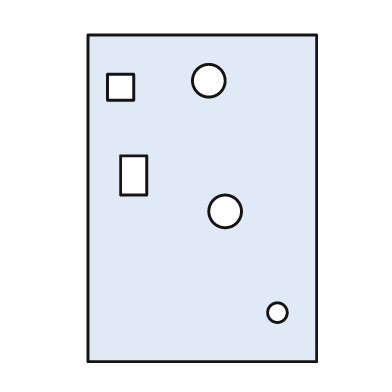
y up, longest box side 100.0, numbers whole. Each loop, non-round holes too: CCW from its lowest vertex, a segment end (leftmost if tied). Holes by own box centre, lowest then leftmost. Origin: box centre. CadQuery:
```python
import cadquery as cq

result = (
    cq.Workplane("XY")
    .moveTo(-35.0, -50.0)
    .lineTo(35.0, -50.0)
    .lineTo(35.0, 50.0)
    .lineTo(-35.0, 50.0)
    .close()
    .moveTo(23.0, -35.0)
    .circle(3.0)
    .moveTo(7.0, -4.0)
    .circle(5.0)
    .moveTo(-25.0, 1.0)
    .lineTo(-17.0, 1.0)
    .lineTo(-17.0, 13.0)
    .lineTo(-25.0, 13.0)
    .close()
    .moveTo(-29.0, 30.0)
    .lineTo(-21.0, 30.0)
    .lineTo(-21.0, 38.0)
    .lineTo(-29.0, 38.0)
    .close()
    .moveTo(2.0, 36.0)
    .circle(5.0)
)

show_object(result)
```